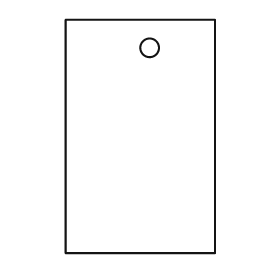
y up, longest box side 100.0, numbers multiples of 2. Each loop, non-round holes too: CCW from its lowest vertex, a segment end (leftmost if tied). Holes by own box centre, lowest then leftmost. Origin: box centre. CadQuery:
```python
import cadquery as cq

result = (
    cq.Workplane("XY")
    .moveTo(-32.0, -50.0)
    .lineTo(32.0, -50.0)
    .lineTo(32.0, 50.0)
    .lineTo(-32.0, 50.0)
    .close()
    .moveTo(4.0, 38.0)
    .circle(4.0)
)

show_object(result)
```